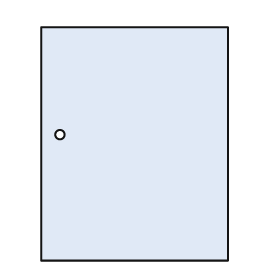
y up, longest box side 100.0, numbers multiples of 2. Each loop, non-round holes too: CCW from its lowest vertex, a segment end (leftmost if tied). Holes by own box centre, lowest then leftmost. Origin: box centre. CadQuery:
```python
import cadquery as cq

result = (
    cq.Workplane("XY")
    .moveTo(-40.0, -50.0)
    .lineTo(40.0, -50.0)
    .lineTo(40.0, 50.0)
    .lineTo(-40.0, 50.0)
    .close()
    .moveTo(-32.0, 4.0)
    .circle(2.0)
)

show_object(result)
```